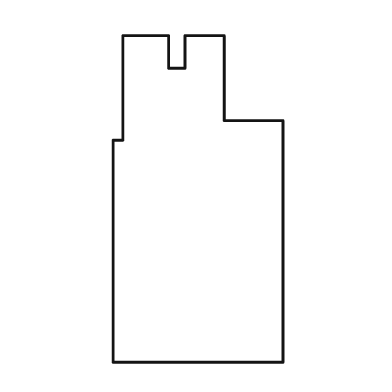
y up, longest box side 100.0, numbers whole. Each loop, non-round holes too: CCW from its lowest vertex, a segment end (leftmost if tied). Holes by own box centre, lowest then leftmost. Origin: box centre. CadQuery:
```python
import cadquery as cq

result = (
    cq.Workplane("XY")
    .moveTo(-26.0, -50.0)
    .lineTo(26.0, -50.0)
    .lineTo(26.0, 24.0)
    .lineTo(8.0, 24.0)
    .lineTo(8.0, 50.0)
    .lineTo(-4.0, 50.0)
    .lineTo(-4.0, 40.0)
    .lineTo(-9.0, 40.0)
    .lineTo(-9.0, 50.0)
    .lineTo(-23.0, 50.0)
    .lineTo(-23.0, 18.0)
    .lineTo(-26.0, 18.0)
    .close()
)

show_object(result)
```